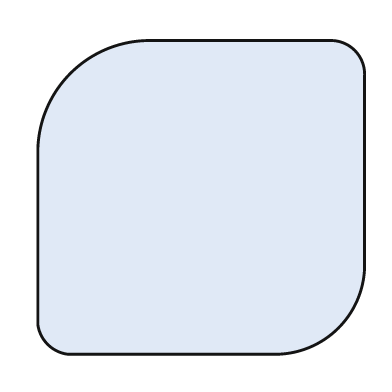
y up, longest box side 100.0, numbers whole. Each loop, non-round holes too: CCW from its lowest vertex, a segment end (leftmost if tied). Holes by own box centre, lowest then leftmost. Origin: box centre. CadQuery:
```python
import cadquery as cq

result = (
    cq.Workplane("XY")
    .moveTo(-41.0, -48.0)
    .lineTo(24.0, -48.0)
    .threePointArc((42.0, -40.0), (50.0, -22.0))
    .lineTo(50.0, 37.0)
    .threePointArc((47.0, 45.0), (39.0, 48.0))
    .lineTo(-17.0, 48.0)
    .threePointArc((-40.0, 38.0), (-50.0, 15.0))
    .lineTo(-50.0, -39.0)
    .threePointArc((-47.0, -45.0), (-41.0, -48.0))
    .close()
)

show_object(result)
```